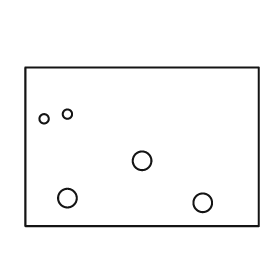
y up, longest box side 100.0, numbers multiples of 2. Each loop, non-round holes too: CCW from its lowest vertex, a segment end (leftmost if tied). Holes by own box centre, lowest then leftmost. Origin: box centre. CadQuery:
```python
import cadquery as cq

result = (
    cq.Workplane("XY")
    .moveTo(-50.0, -34.0)
    .lineTo(50.0, -34.0)
    .lineTo(50.0, 34.0)
    .lineTo(-50.0, 34.0)
    .close()
    .moveTo(26.0, -24.0)
    .circle(4.0)
    .moveTo(-32.0, -22.0)
    .circle(4.0)
    .moveTo(0.0, -6.0)
    .circle(4.0)
    .moveTo(-42.0, 12.0)
    .circle(2.0)
    .moveTo(-32.0, 14.0)
    .circle(2.0)
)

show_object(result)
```